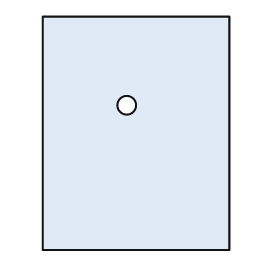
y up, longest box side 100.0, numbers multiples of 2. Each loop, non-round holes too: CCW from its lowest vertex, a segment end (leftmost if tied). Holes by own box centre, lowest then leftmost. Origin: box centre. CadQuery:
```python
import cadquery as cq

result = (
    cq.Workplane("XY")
    .moveTo(-40.0, -50.0)
    .lineTo(40.0, -50.0)
    .lineTo(40.0, 50.0)
    .lineTo(-40.0, 50.0)
    .close()
    .moveTo(-4.0, 12.0)
    .circle(4.0)
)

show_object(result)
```